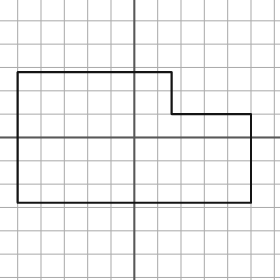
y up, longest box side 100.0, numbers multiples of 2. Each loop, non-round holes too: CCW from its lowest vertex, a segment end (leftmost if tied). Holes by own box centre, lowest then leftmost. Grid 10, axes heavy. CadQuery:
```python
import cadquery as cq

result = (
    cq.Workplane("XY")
    .moveTo(-50.0, -28.0)
    .lineTo(50.0, -28.0)
    .lineTo(50.0, 10.0)
    .lineTo(16.0, 10.0)
    .lineTo(16.0, 28.0)
    .lineTo(-50.0, 28.0)
    .close()
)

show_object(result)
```